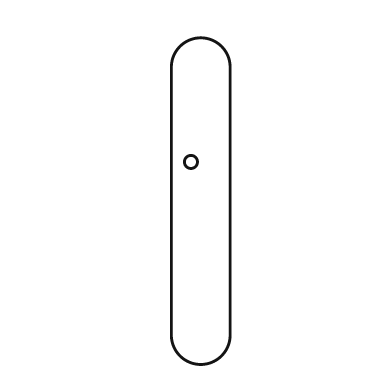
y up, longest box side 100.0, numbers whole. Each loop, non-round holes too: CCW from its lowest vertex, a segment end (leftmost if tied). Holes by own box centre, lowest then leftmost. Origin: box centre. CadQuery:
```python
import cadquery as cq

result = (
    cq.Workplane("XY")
    .moveTo(-9.0, -41.0)
    .threePointArc((0.0, -50.0), (9.0, -41.0))
    .lineTo(9.0, 41.0)
    .threePointArc((0.0, 50.0), (-9.0, 41.0))
    .close()
    .moveTo(-3.0, 12.0)
    .circle(2.0)
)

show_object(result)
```